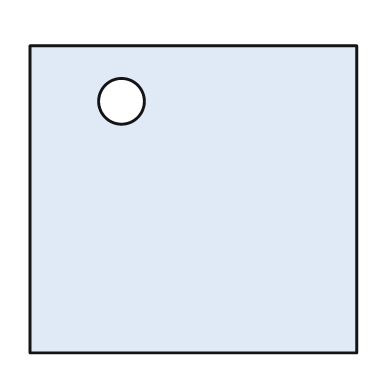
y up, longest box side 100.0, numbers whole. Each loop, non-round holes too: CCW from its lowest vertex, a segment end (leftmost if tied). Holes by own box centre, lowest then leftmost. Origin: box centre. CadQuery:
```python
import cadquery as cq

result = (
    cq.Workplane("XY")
    .moveTo(-50.0, -47.0)
    .lineTo(50.0, -47.0)
    .lineTo(50.0, 47.0)
    .lineTo(-50.0, 47.0)
    .close()
    .moveTo(-22.0, 30.0)
    .circle(7.0)
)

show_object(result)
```